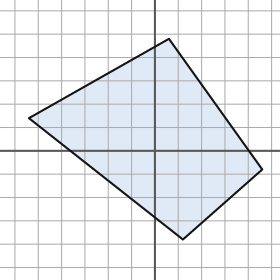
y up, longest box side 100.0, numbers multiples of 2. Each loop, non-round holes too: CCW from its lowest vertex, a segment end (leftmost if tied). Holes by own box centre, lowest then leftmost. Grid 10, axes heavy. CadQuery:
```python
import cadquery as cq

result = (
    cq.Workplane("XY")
    .moveTo(12.0, -38.0)
    .lineTo(46.0, -8.0)
    .lineTo(6.0, 48.0)
    .lineTo(-54.0, 14.0)
    .close()
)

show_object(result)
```